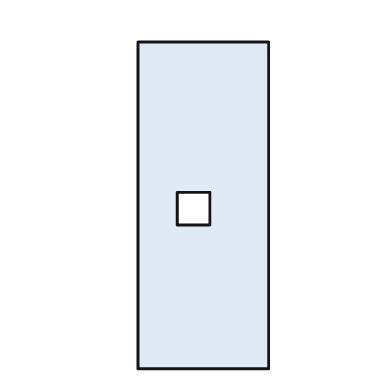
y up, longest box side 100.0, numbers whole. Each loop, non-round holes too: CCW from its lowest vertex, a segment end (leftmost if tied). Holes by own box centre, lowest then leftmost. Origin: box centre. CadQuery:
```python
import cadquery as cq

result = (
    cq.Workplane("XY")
    .moveTo(-20.0, -50.0)
    .lineTo(20.0, -50.0)
    .lineTo(20.0, 50.0)
    .lineTo(-20.0, 50.0)
    .close()
    .moveTo(-8.0, -6.0)
    .lineTo(2.0, -6.0)
    .lineTo(2.0, 4.0)
    .lineTo(-8.0, 4.0)
    .close()
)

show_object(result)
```